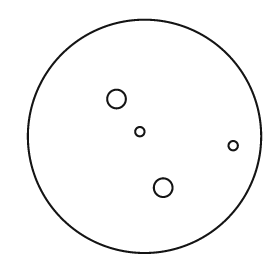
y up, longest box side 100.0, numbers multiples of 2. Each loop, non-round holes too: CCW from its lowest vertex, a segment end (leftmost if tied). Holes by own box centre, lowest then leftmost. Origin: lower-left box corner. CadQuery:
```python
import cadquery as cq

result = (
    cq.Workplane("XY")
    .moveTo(50.0, 50.0)
    .circle(50.0)
    .moveTo(58.0, 28.0)
    .circle(4.0)
    .moveTo(88.0, 46.0)
    .circle(2.0)
    .moveTo(48.0, 52.0)
    .circle(2.0)
    .moveTo(38.0, 66.0)
    .circle(4.0)
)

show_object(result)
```